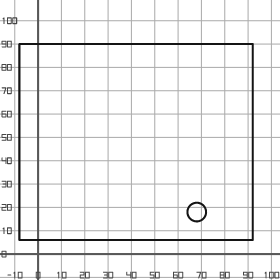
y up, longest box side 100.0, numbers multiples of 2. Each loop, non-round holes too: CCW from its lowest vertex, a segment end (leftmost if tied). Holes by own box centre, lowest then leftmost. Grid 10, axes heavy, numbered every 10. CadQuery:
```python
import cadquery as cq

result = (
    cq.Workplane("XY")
    .moveTo(-8.0, 6.0)
    .lineTo(92.0, 6.0)
    .lineTo(92.0, 90.0)
    .lineTo(-8.0, 90.0)
    .close()
    .moveTo(68.0, 18.0)
    .circle(4.0)
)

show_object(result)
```